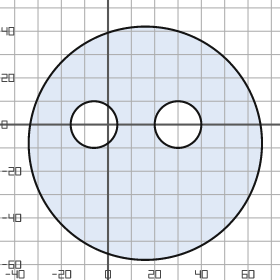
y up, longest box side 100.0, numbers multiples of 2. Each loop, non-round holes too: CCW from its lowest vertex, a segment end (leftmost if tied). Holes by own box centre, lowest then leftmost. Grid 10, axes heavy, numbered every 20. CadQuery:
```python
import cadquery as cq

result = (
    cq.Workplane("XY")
    .moveTo(16.0, -8.0)
    .circle(50.0)
    .moveTo(-6.0, 0.0)
    .circle(10.0)
    .moveTo(30.0, 0.0)
    .circle(10.0)
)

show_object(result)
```